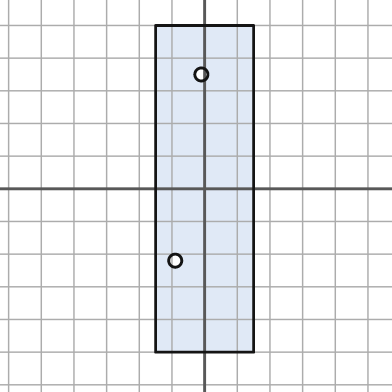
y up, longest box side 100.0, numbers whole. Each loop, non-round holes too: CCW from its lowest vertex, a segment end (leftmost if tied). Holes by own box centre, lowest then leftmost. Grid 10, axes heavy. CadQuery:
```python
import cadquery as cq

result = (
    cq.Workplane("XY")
    .moveTo(-15.0, -50.0)
    .lineTo(15.0, -50.0)
    .lineTo(15.0, 50.0)
    .lineTo(-15.0, 50.0)
    .close()
    .moveTo(-9.0, -22.0)
    .circle(2.0)
    .moveTo(-1.0, 35.0)
    .circle(2.0)
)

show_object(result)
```